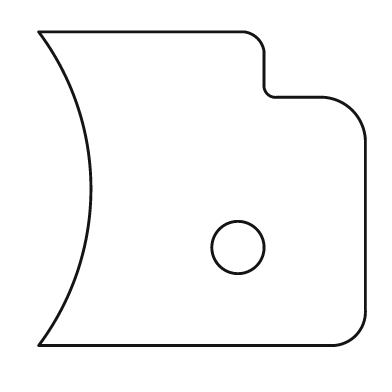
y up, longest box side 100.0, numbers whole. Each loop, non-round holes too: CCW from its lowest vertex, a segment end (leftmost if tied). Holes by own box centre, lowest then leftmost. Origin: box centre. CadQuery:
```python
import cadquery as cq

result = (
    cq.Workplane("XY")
    .moveTo(-50.0, -48.0)
    .lineTo(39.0, -48.0)
    .threePointArc((47.0, -45.0), (50.0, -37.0))
    .lineTo(50.0, 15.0)
    .threePointArc((46.0, 24.0), (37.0, 28.0))
    .lineTo(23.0, 28.0)
    .threePointArc((20.0, 29.0), (19.0, 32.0))
    .lineTo(19.0, 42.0)
    .threePointArc((17.0, 46.0), (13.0, 48.0))
    .lineTo(-50.0, 48.0)
    .threePointArc((-34.0, 0.0), (-50.0, -48.0))
    .close()
    .moveTo(11.0, -18.0)
    .circle(8.0)
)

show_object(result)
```